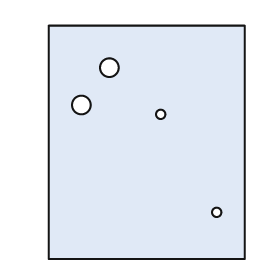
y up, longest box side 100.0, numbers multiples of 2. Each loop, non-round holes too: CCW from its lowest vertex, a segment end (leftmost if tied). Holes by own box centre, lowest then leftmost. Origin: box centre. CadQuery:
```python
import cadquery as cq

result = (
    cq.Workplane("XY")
    .moveTo(-42.0, -50.0)
    .lineTo(42.0, -50.0)
    .lineTo(42.0, 50.0)
    .lineTo(-42.0, 50.0)
    .close()
    .moveTo(30.0, -30.0)
    .circle(2.0)
    .moveTo(6.0, 12.0)
    .circle(2.0)
    .moveTo(-28.0, 16.0)
    .circle(4.0)
    .moveTo(-16.0, 32.0)
    .circle(4.0)
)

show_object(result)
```